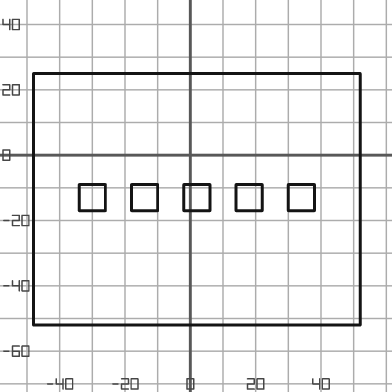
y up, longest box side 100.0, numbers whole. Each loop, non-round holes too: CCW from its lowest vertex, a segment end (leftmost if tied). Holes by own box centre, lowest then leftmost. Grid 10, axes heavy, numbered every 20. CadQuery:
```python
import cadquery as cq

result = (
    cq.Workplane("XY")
    .moveTo(-48.0, -52.0)
    .lineTo(52.0, -52.0)
    .lineTo(52.0, 25.0)
    .lineTo(-48.0, 25.0)
    .close()
    .moveTo(-34.0, -17.0)
    .lineTo(-26.0, -17.0)
    .lineTo(-26.0, -9.0)
    .lineTo(-34.0, -9.0)
    .close()
    .moveTo(-18.0, -17.0)
    .lineTo(-10.0, -17.0)
    .lineTo(-10.0, -9.0)
    .lineTo(-18.0, -9.0)
    .close()
    .moveTo(-2.0, -17.0)
    .lineTo(6.0, -17.0)
    .lineTo(6.0, -9.0)
    .lineTo(-2.0, -9.0)
    .close()
    .moveTo(14.0, -17.0)
    .lineTo(22.0, -17.0)
    .lineTo(22.0, -9.0)
    .lineTo(14.0, -9.0)
    .close()
    .moveTo(30.0, -17.0)
    .lineTo(38.0, -17.0)
    .lineTo(38.0, -9.0)
    .lineTo(30.0, -9.0)
    .close()
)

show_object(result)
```